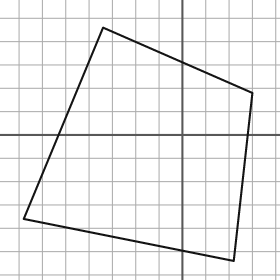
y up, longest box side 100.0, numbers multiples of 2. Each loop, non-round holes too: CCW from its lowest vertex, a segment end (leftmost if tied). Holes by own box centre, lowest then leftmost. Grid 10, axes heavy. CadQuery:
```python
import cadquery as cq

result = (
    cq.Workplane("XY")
    .moveTo(22.0, -54.0)
    .lineTo(30.0, 18.0)
    .lineTo(-34.0, 46.0)
    .lineTo(-68.0, -36.0)
    .close()
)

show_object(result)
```